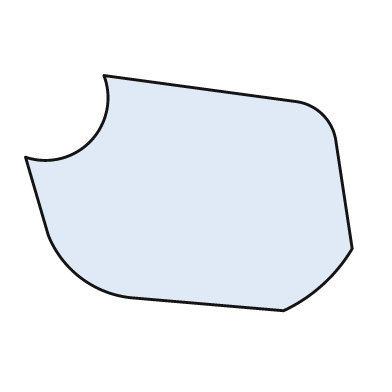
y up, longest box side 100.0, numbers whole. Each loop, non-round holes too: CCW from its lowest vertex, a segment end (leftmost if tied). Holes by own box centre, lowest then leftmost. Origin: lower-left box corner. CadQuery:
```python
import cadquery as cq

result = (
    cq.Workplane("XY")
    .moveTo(79.0, 0.0)
    .threePointArc((91.0, 8.0), (100.0, 19.0))
    .lineTo(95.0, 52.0)
    .threePointArc((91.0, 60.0), (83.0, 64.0))
    .lineTo(24.0, 72.0)
    .threePointArc((20.0, 52.0), (0.0, 47.0))
    .lineTo(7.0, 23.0)
    .threePointArc((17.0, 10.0), (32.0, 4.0))
    .close()
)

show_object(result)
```